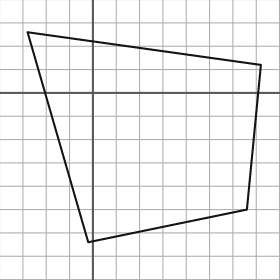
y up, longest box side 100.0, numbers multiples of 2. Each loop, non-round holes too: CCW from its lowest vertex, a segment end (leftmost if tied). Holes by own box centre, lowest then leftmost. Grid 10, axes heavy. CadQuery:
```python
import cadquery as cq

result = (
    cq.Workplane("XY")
    .moveTo(-2.0, -64.0)
    .lineTo(66.0, -50.0)
    .lineTo(72.0, 12.0)
    .lineTo(-28.0, 26.0)
    .close()
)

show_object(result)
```